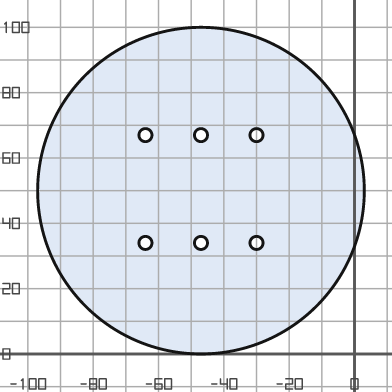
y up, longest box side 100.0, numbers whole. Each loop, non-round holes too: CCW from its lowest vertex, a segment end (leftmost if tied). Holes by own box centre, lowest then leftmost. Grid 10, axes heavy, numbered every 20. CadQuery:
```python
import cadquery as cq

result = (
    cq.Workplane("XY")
    .moveTo(-47.0, 50.0)
    .circle(50.0)
    .moveTo(-64.0, 34.0)
    .circle(2.0)
    .moveTo(-47.0, 34.0)
    .circle(2.0)
    .moveTo(-30.0, 34.0)
    .circle(2.0)
    .moveTo(-64.0, 67.0)
    .circle(2.0)
    .moveTo(-47.0, 67.0)
    .circle(2.0)
    .moveTo(-30.0, 67.0)
    .circle(2.0)
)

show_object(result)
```